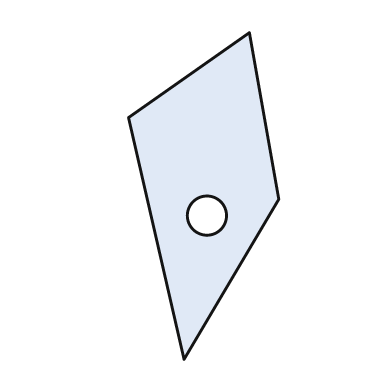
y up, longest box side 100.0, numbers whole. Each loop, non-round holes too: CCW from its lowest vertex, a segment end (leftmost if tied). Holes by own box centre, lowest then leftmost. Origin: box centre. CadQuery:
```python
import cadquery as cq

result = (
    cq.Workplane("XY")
    .moveTo(-6.0, -50.0)
    .lineTo(23.0, -1.0)
    .lineTo(14.0, 50.0)
    .lineTo(-23.0, 24.0)
    .close()
    .moveTo(1.0, -6.0)
    .circle(6.0)
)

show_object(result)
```